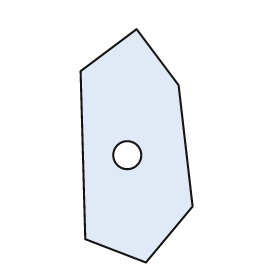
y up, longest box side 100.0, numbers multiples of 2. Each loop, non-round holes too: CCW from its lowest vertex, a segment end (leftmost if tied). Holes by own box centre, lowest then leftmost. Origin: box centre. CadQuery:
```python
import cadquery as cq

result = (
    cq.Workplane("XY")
    .moveTo(4.0, -50.0)
    .lineTo(24.0, -26.0)
    .lineTo(18.0, 26.0)
    .lineTo(0.0, 50.0)
    .lineTo(-24.0, 32.0)
    .lineTo(-22.0, -40.0)
    .close()
    .moveTo(-4.0, -4.0)
    .circle(6.0)
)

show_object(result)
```